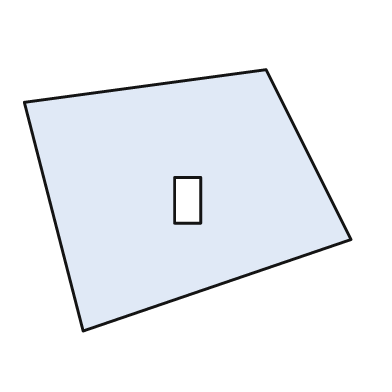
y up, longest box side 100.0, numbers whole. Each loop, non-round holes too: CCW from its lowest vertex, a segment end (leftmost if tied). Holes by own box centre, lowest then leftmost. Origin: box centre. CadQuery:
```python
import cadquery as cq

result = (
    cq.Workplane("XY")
    .moveTo(-32.0, -40.0)
    .lineTo(50.0, -12.0)
    .lineTo(24.0, 40.0)
    .lineTo(-50.0, 30.0)
    .close()
    .moveTo(-4.0, -7.0)
    .lineTo(4.0, -7.0)
    .lineTo(4.0, 7.0)
    .lineTo(-4.0, 7.0)
    .close()
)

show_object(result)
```